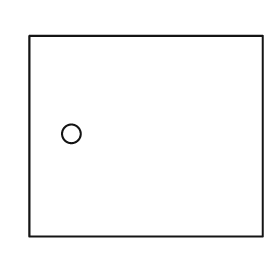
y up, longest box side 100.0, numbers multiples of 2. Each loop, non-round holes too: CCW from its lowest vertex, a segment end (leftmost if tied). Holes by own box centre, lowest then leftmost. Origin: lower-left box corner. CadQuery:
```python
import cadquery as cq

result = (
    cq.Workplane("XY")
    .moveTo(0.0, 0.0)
    .lineTo(100.0, 0.0)
    .lineTo(100.0, 86.0)
    .lineTo(0.0, 86.0)
    .close()
    .moveTo(18.0, 44.0)
    .circle(4.0)
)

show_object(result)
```